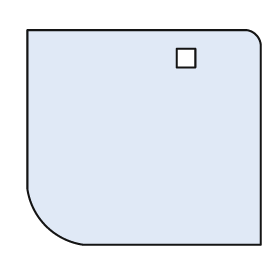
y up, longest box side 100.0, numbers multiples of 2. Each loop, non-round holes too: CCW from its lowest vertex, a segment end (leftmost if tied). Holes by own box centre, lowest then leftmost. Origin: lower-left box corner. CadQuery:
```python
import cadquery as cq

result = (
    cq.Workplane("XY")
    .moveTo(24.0, 0.0)
    .lineTo(100.0, 0.0)
    .lineTo(100.0, 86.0)
    .threePointArc((98.0, 90.0), (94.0, 92.0))
    .lineTo(0.0, 92.0)
    .lineTo(0.0, 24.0)
    .threePointArc((8.0, 8.0), (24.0, 0.0))
    .close()
    .moveTo(64.0, 76.0)
    .lineTo(72.0, 76.0)
    .lineTo(72.0, 84.0)
    .lineTo(64.0, 84.0)
    .close()
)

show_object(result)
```